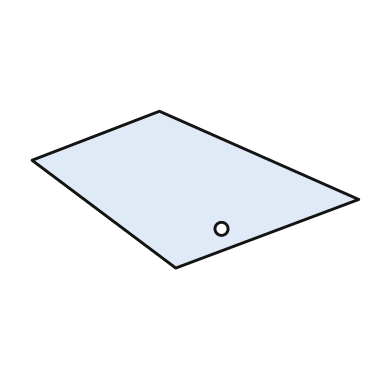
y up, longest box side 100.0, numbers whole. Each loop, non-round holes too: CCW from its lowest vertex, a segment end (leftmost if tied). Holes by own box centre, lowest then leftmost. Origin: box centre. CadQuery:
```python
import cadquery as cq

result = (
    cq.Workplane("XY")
    .moveTo(-6.0, -24.0)
    .lineTo(50.0, -3.0)
    .lineTo(-11.0, 24.0)
    .lineTo(-50.0, 9.0)
    .close()
    .moveTo(8.0, -12.0)
    .circle(2.0)
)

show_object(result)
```